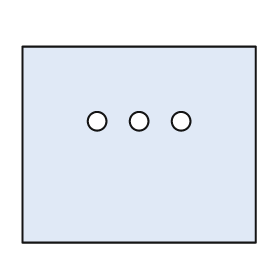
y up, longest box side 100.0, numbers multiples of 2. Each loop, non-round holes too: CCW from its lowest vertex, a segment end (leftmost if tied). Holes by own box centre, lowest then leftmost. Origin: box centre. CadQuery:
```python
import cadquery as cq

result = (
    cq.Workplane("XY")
    .moveTo(-50.0, -42.0)
    .lineTo(50.0, -42.0)
    .lineTo(50.0, 42.0)
    .lineTo(-50.0, 42.0)
    .close()
    .moveTo(-18.0, 10.0)
    .circle(4.0)
    .moveTo(0.0, 10.0)
    .circle(4.0)
    .moveTo(18.0, 10.0)
    .circle(4.0)
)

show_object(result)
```